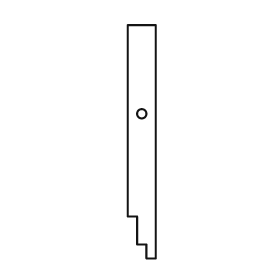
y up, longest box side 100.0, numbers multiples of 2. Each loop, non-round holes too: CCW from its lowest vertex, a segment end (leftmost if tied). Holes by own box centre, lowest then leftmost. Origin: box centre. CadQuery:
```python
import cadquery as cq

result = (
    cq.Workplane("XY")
    .moveTo(2.0, -50.0)
    .lineTo(6.0, -50.0)
    .lineTo(6.0, 50.0)
    .lineTo(-6.0, 50.0)
    .lineTo(-6.0, -32.0)
    .lineTo(-2.0, -32.0)
    .lineTo(-2.0, -44.0)
    .lineTo(2.0, -44.0)
    .close()
    .moveTo(0.0, 12.0)
    .circle(2.0)
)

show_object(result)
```